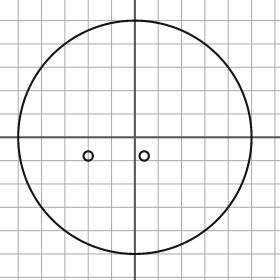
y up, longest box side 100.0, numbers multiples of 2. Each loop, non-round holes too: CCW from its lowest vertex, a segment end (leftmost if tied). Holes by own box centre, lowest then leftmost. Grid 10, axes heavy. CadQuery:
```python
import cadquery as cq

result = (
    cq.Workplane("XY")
    .moveTo(0.0, 0.0)
    .circle(50.0)
    .moveTo(-20.0, -8.0)
    .circle(2.0)
    .moveTo(4.0, -8.0)
    .circle(2.0)
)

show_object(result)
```